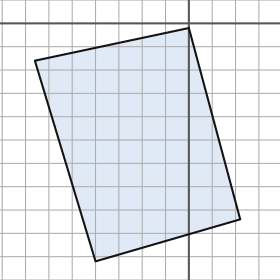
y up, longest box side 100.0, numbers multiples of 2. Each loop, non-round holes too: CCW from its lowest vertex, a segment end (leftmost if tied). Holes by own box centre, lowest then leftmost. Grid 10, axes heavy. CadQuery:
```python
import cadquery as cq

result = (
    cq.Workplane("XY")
    .moveTo(-40.0, -102.0)
    .lineTo(22.0, -84.0)
    .lineTo(0.0, -2.0)
    .lineTo(-66.0, -16.0)
    .close()
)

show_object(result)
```